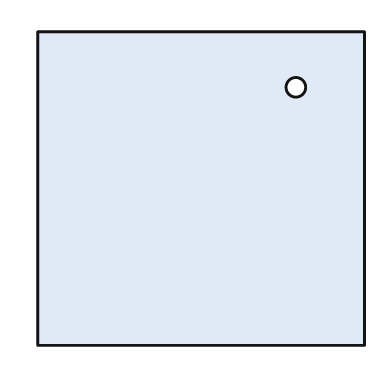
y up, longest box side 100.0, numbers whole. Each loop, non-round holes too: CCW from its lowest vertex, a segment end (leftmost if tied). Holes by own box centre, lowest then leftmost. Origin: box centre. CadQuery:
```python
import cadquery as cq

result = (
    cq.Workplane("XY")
    .moveTo(-50.0, -48.0)
    .lineTo(50.0, -48.0)
    .lineTo(50.0, 48.0)
    .lineTo(-50.0, 48.0)
    .close()
    .moveTo(29.0, 31.0)
    .circle(3.0)
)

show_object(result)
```